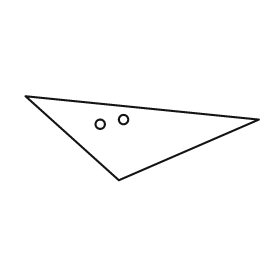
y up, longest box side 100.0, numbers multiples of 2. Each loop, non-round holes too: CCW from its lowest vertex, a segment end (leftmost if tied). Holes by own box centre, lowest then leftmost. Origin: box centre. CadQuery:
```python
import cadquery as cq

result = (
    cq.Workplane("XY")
    .moveTo(-10.0, -18.0)
    .lineTo(50.0, 8.0)
    .lineTo(-50.0, 18.0)
    .close()
    .moveTo(-18.0, 6.0)
    .circle(2.0)
    .moveTo(-8.0, 8.0)
    .circle(2.0)
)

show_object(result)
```